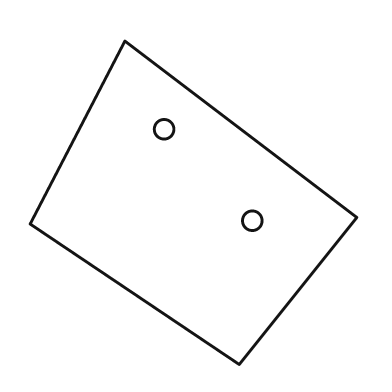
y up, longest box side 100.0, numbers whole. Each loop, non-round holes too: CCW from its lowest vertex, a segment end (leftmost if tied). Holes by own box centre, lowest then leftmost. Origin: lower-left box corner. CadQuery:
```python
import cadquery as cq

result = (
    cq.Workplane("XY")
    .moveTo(64.0, 0.0)
    .lineTo(100.0, 45.0)
    .lineTo(29.0, 99.0)
    .lineTo(0.0, 43.0)
    .close()
    .moveTo(68.0, 44.0)
    .circle(3.0)
    .moveTo(41.0, 72.0)
    .circle(3.0)
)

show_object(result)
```